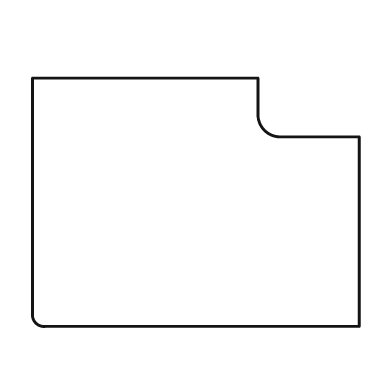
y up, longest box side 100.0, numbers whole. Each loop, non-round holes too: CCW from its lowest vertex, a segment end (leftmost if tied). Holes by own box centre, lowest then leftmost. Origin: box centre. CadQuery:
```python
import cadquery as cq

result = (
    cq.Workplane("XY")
    .moveTo(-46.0, -38.0)
    .lineTo(50.0, -38.0)
    .lineTo(50.0, 20.0)
    .lineTo(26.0, 20.0)
    .threePointArc((21.0, 22.0), (19.0, 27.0))
    .lineTo(19.0, 38.0)
    .lineTo(-50.0, 38.0)
    .lineTo(-50.0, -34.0)
    .threePointArc((-49.0, -37.0), (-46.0, -38.0))
    .close()
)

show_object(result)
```